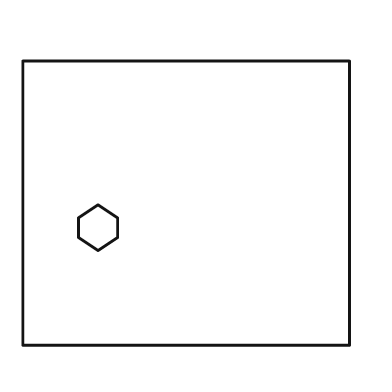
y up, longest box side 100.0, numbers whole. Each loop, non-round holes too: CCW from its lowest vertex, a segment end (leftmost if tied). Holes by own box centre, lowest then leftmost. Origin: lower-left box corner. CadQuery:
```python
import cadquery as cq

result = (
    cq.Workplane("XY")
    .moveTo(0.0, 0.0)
    .lineTo(100.0, 0.0)
    .lineTo(100.0, 87.0)
    .lineTo(0.0, 87.0)
    .close()
    .moveTo(23.0, 29.0)
    .lineTo(29.0, 33.0)
    .lineTo(29.0, 39.0)
    .lineTo(23.0, 43.0)
    .lineTo(17.0, 39.0)
    .lineTo(17.0, 33.0)
    .close()
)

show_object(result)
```